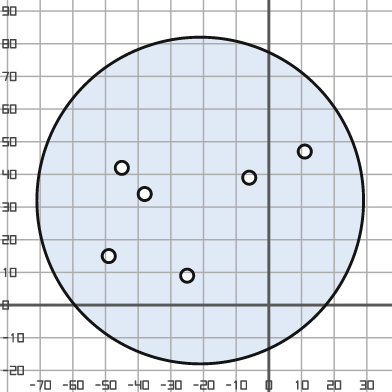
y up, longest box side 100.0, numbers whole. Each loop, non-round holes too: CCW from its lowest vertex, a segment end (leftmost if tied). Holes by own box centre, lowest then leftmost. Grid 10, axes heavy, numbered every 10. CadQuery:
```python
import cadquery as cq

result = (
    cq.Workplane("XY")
    .moveTo(-21.0, 32.0)
    .circle(50.0)
    .moveTo(-25.0, 9.0)
    .circle(2.0)
    .moveTo(-49.0, 15.0)
    .circle(2.0)
    .moveTo(-38.0, 34.0)
    .circle(2.0)
    .moveTo(-6.0, 39.0)
    .circle(2.0)
    .moveTo(-45.0, 42.0)
    .circle(2.0)
    .moveTo(11.0, 47.0)
    .circle(2.0)
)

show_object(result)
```